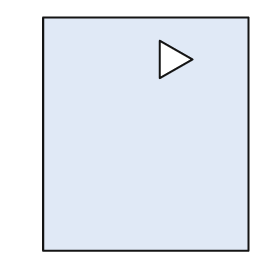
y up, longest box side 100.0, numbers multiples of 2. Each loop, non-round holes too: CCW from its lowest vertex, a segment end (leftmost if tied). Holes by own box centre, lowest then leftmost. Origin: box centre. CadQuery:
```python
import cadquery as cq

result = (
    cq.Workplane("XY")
    .moveTo(-44.0, -50.0)
    .lineTo(44.0, -50.0)
    .lineTo(44.0, 50.0)
    .lineTo(-44.0, 50.0)
    .close()
    .moveTo(6.0, 24.0)
    .lineTo(20.0, 32.0)
    .lineTo(6.0, 40.0)
    .close()
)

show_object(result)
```